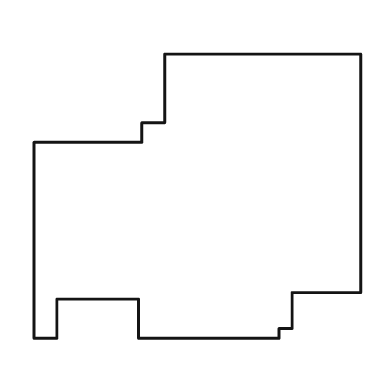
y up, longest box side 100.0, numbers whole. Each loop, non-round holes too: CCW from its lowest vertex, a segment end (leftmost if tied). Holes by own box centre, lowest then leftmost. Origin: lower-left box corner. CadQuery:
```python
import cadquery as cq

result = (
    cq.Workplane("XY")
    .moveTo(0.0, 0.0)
    .lineTo(7.0, 0.0)
    .lineTo(7.0, 12.0)
    .lineTo(32.0, 12.0)
    .lineTo(32.0, 0.0)
    .lineTo(75.0, 0.0)
    .lineTo(75.0, 3.0)
    .lineTo(79.0, 3.0)
    .lineTo(79.0, 14.0)
    .lineTo(100.0, 14.0)
    .lineTo(100.0, 87.0)
    .lineTo(40.0, 87.0)
    .lineTo(40.0, 66.0)
    .lineTo(33.0, 66.0)
    .lineTo(33.0, 60.0)
    .lineTo(0.0, 60.0)
    .close()
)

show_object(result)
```